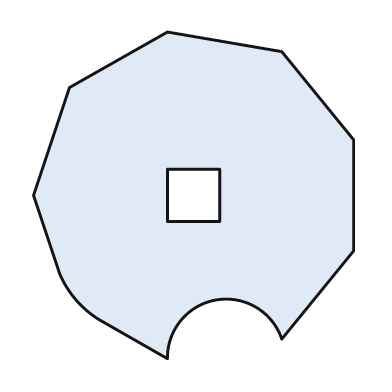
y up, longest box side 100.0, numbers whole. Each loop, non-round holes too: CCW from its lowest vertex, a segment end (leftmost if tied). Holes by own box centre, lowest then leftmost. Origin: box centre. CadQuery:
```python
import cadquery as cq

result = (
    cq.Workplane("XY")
    .moveTo(-8.0, -50.0)
    .threePointArc((7.0, -32.0), (27.0, -44.0))
    .lineTo(49.0, -17.0)
    .lineTo(49.0, 17.0)
    .lineTo(27.0, 44.0)
    .lineTo(-8.0, 50.0)
    .lineTo(-38.0, 33.0)
    .lineTo(-49.0, 0.0)
    .lineTo(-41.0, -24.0)
    .threePointArc((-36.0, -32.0), (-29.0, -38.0))
    .close()
    .moveTo(-8.0, -8.0)
    .lineTo(8.0, -8.0)
    .lineTo(8.0, 8.0)
    .lineTo(-8.0, 8.0)
    .close()
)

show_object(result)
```